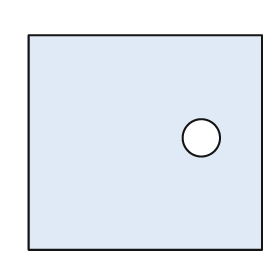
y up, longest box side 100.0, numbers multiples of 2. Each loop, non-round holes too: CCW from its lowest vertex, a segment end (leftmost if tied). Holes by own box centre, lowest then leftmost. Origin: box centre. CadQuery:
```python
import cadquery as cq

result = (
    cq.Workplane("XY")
    .moveTo(-50.0, -46.0)
    .lineTo(50.0, -46.0)
    .lineTo(50.0, 46.0)
    .lineTo(-50.0, 46.0)
    .close()
    .moveTo(24.0, 2.0)
    .circle(8.0)
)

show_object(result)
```